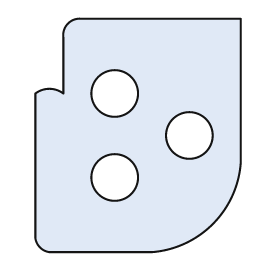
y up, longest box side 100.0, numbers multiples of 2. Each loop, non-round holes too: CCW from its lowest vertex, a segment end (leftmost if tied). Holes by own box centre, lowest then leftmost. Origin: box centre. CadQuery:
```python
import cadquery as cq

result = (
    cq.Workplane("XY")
    .moveTo(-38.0, -50.0)
    .lineTo(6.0, -50.0)
    .threePointArc((32.0, -38.0), (44.0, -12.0))
    .lineTo(44.0, 50.0)
    .lineTo(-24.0, 50.0)
    .threePointArc((-30.0, 48.0), (-32.0, 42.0))
    .lineTo(-32.0, 18.0)
    .threePointArc((-38.0, 20.0), (-44.0, 18.0))
    .lineTo(-44.0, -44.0)
    .threePointArc((-42.0, -48.0), (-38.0, -50.0))
    .close()
    .moveTo(-10.0, -18.0)
    .circle(10.0)
    .moveTo(22.0, 0.0)
    .circle(10.0)
    .moveTo(-10.0, 18.0)
    .circle(10.0)
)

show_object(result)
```